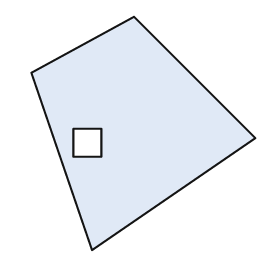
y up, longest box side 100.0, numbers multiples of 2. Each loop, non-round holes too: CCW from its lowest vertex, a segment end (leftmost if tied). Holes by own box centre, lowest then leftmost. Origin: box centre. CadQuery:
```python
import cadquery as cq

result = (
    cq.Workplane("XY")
    .moveTo(-22.0, -50.0)
    .lineTo(48.0, -2.0)
    .lineTo(-4.0, 50.0)
    .lineTo(-48.0, 26.0)
    .close()
    .moveTo(-30.0, -10.0)
    .lineTo(-18.0, -10.0)
    .lineTo(-18.0, 2.0)
    .lineTo(-30.0, 2.0)
    .close()
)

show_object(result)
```